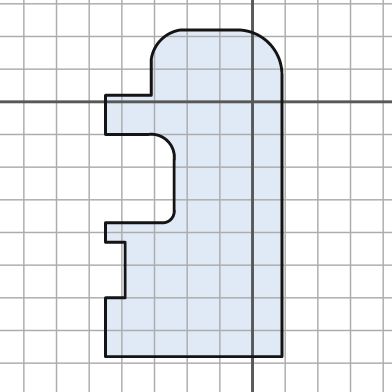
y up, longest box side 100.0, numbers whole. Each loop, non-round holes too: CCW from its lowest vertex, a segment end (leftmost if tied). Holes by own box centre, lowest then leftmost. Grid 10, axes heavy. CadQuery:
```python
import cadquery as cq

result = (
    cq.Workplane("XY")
    .moveTo(-45.0, -78.0)
    .lineTo(9.0, -78.0)
    .lineTo(9.0, 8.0)
    .threePointArc((5.0, 18.0), (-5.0, 22.0))
    .lineTo(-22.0, 22.0)
    .threePointArc((-28.0, 19.0), (-31.0, 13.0))
    .lineTo(-31.0, 2.0)
    .lineTo(-45.0, 2.0)
    .lineTo(-45.0, -10.0)
    .lineTo(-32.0, -10.0)
    .threePointArc((-26.0, -12.0), (-24.0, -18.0))
    .lineTo(-24.0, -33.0)
    .threePointArc((-25.0, -36.0), (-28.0, -37.0))
    .lineTo(-45.0, -37.0)
    .lineTo(-45.0, -43.0)
    .lineTo(-39.0, -43.0)
    .lineTo(-39.0, -60.0)
    .lineTo(-45.0, -60.0)
    .close()
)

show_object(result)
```